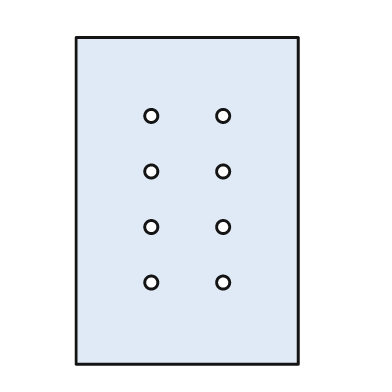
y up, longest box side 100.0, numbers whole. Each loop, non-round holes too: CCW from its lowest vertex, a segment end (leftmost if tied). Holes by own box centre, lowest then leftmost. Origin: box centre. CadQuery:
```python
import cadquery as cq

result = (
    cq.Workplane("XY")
    .moveTo(-34.0, -50.0)
    .lineTo(34.0, -50.0)
    .lineTo(34.0, 50.0)
    .lineTo(-34.0, 50.0)
    .close()
    .moveTo(-11.0, -25.0)
    .circle(2.0)
    .moveTo(11.0, -25.0)
    .circle(2.0)
    .moveTo(-11.0, -8.0)
    .circle(2.0)
    .moveTo(11.0, -8.0)
    .circle(2.0)
    .moveTo(-11.0, 9.0)
    .circle(2.0)
    .moveTo(11.0, 9.0)
    .circle(2.0)
    .moveTo(-11.0, 26.0)
    .circle(2.0)
    .moveTo(11.0, 26.0)
    .circle(2.0)
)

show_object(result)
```